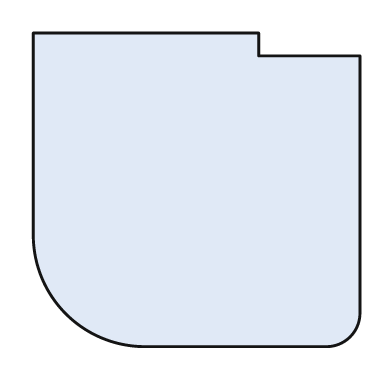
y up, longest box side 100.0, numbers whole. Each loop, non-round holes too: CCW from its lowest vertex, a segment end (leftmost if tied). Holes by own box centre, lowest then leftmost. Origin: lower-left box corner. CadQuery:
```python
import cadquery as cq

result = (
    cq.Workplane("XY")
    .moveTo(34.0, 0.0)
    .lineTo(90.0, 0.0)
    .threePointArc((97.0, 3.0), (100.0, 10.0))
    .lineTo(100.0, 89.0)
    .lineTo(69.0, 89.0)
    .lineTo(69.0, 96.0)
    .lineTo(0.0, 96.0)
    .lineTo(0.0, 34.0)
    .threePointArc((10.0, 10.0), (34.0, 0.0))
    .close()
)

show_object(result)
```